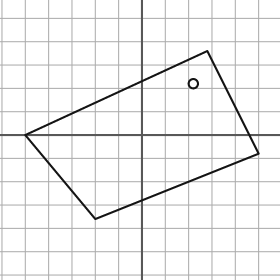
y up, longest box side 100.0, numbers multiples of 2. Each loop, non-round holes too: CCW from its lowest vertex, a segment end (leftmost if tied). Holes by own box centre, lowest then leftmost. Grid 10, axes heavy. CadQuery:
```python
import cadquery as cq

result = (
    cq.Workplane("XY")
    .moveTo(-20.0, -36.0)
    .lineTo(50.0, -8.0)
    .lineTo(28.0, 36.0)
    .lineTo(-50.0, 0.0)
    .close()
    .moveTo(22.0, 22.0)
    .circle(2.0)
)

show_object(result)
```